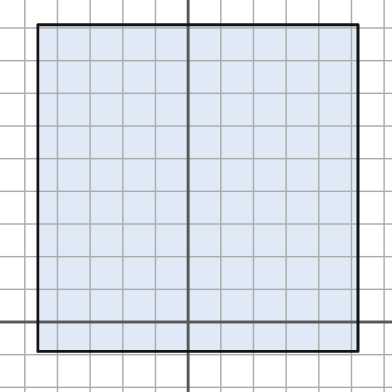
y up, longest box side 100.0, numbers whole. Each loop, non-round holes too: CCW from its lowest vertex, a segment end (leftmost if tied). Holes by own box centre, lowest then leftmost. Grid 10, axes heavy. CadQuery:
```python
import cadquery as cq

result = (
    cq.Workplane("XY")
    .moveTo(-46.0, -9.0)
    .lineTo(52.0, -9.0)
    .lineTo(52.0, 91.0)
    .lineTo(-46.0, 91.0)
    .close()
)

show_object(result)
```